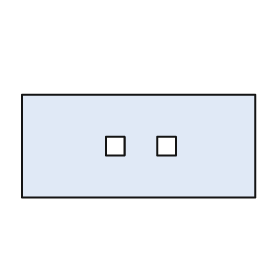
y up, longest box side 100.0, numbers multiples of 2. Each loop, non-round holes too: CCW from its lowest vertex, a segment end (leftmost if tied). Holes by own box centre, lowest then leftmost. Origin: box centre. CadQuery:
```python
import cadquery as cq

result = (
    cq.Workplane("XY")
    .moveTo(-50.0, -22.0)
    .lineTo(50.0, -22.0)
    .lineTo(50.0, 22.0)
    .lineTo(-50.0, 22.0)
    .close()
    .moveTo(-14.0, -4.0)
    .lineTo(-6.0, -4.0)
    .lineTo(-6.0, 4.0)
    .lineTo(-14.0, 4.0)
    .close()
    .moveTo(8.0, -4.0)
    .lineTo(16.0, -4.0)
    .lineTo(16.0, 4.0)
    .lineTo(8.0, 4.0)
    .close()
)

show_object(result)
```